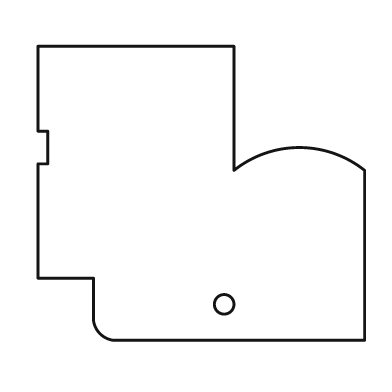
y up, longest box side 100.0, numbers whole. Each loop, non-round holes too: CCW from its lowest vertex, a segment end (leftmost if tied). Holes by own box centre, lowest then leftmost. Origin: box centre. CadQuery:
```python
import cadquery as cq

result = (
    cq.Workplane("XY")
    .moveTo(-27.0, -45.0)
    .lineTo(50.0, -45.0)
    .lineTo(50.0, 7.0)
    .threePointArc((30.0, 14.0), (10.0, 7.0))
    .lineTo(10.0, 45.0)
    .lineTo(-50.0, 45.0)
    .lineTo(-50.0, 19.0)
    .lineTo(-47.0, 19.0)
    .lineTo(-47.0, 9.0)
    .lineTo(-50.0, 9.0)
    .lineTo(-50.0, -26.0)
    .lineTo(-33.0, -26.0)
    .lineTo(-33.0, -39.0)
    .threePointArc((-31.0, -43.0), (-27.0, -45.0))
    .close()
    .moveTo(7.0, -34.0)
    .circle(3.0)
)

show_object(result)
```